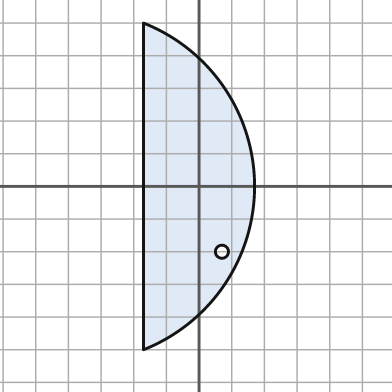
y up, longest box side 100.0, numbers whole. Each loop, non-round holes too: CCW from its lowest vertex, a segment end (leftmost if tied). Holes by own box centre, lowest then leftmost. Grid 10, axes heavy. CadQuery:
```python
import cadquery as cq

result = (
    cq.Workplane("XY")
    .moveTo(-17.0, -50.0)
    .threePointArc((17.0, 0.0), (-17.0, 50.0))
    .close()
    .moveTo(7.0, -20.0)
    .circle(2.0)
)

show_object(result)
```